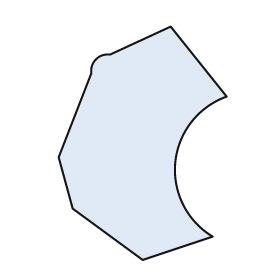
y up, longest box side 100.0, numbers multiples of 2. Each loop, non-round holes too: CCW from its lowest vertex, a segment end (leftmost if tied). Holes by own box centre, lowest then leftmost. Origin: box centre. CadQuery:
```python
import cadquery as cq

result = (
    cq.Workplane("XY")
    .moveTo(0.0, -50.0)
    .lineTo(30.0, -40.0)
    .threePointArc((14.0, -8.0), (36.0, 20.0))
    .lineTo(12.0, 50.0)
    .lineTo(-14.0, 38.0)
    .threePointArc((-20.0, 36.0), (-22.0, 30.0))
    .lineTo(-36.0, -6.0)
    .lineTo(-30.0, -28.0)
    .close()
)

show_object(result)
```